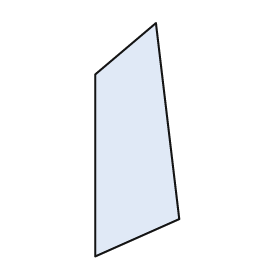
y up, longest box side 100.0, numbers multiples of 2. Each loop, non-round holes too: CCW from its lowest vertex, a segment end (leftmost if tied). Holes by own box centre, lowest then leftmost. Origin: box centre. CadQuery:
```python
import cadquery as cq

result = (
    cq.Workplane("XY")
    .moveTo(-18.0, -50.0)
    .lineTo(18.0, -34.0)
    .lineTo(8.0, 50.0)
    .lineTo(-18.0, 28.0)
    .close()
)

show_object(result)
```